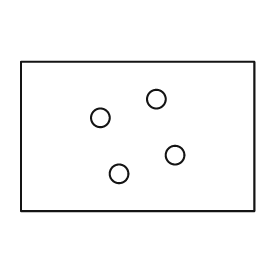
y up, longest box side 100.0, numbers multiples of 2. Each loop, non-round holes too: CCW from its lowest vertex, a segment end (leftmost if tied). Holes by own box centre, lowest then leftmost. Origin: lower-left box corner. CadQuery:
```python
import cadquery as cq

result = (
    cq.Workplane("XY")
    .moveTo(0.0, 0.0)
    .lineTo(100.0, 0.0)
    .lineTo(100.0, 64.0)
    .lineTo(0.0, 64.0)
    .close()
    .moveTo(42.0, 16.0)
    .circle(4.0)
    .moveTo(66.0, 24.0)
    .circle(4.0)
    .moveTo(34.0, 40.0)
    .circle(4.0)
    .moveTo(58.0, 48.0)
    .circle(4.0)
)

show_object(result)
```